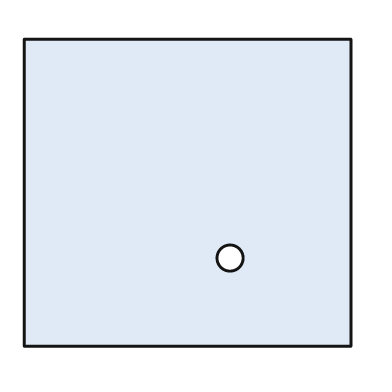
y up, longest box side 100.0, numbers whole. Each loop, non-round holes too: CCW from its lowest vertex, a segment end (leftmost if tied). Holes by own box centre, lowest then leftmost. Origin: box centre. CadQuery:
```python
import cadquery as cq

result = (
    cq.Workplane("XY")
    .moveTo(-50.0, -47.0)
    .lineTo(50.0, -47.0)
    .lineTo(50.0, 47.0)
    .lineTo(-50.0, 47.0)
    .close()
    .moveTo(13.0, -20.0)
    .circle(4.0)
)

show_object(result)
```